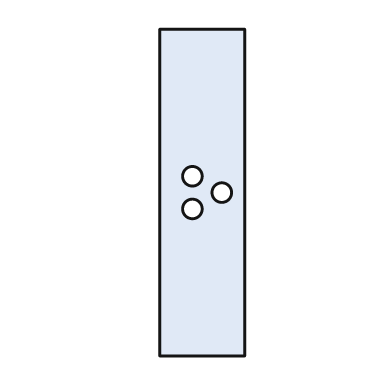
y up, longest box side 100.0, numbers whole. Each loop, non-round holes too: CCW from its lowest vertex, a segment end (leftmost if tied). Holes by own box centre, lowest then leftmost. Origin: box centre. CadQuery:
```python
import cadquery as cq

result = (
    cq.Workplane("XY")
    .moveTo(-13.0, -50.0)
    .lineTo(13.0, -50.0)
    .lineTo(13.0, 50.0)
    .lineTo(-13.0, 50.0)
    .close()
    .moveTo(-3.0, -5.0)
    .circle(3.0)
    .moveTo(6.0, 0.0)
    .circle(3.0)
    .moveTo(-3.0, 5.0)
    .circle(3.0)
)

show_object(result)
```